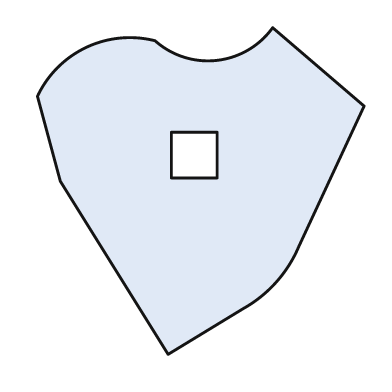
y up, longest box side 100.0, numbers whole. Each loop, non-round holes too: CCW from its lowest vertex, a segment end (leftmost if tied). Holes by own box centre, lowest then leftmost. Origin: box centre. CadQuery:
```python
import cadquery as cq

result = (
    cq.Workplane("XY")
    .moveTo(-10.0, -50.0)
    .lineTo(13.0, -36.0)
    .threePointArc((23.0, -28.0), (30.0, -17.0))
    .lineTo(50.0, 26.0)
    .lineTo(22.0, 50.0)
    .threePointArc((5.0, 40.0), (-14.0, 46.0))
    .threePointArc((-35.0, 44.0), (-50.0, 29.0))
    .lineTo(-43.0, 3.0)
    .close()
    .moveTo(-9.0, 4.0)
    .lineTo(5.0, 4.0)
    .lineTo(5.0, 18.0)
    .lineTo(-9.0, 18.0)
    .close()
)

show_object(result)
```